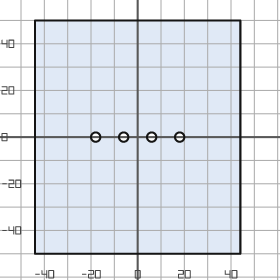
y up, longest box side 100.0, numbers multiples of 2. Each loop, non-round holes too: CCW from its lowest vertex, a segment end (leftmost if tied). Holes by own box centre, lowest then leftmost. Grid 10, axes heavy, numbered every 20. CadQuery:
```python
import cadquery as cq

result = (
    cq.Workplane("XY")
    .moveTo(-44.0, -50.0)
    .lineTo(44.0, -50.0)
    .lineTo(44.0, 50.0)
    .lineTo(-44.0, 50.0)
    .close()
    .moveTo(-18.0, 0.0)
    .circle(2.0)
    .moveTo(-6.0, 0.0)
    .circle(2.0)
    .moveTo(6.0, 0.0)
    .circle(2.0)
    .moveTo(18.0, 0.0)
    .circle(2.0)
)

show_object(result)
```